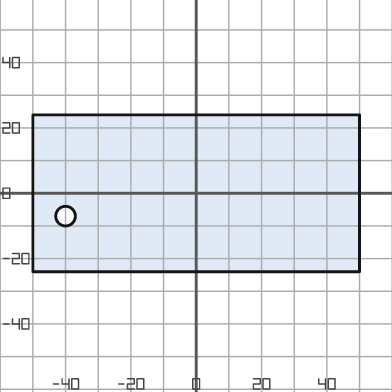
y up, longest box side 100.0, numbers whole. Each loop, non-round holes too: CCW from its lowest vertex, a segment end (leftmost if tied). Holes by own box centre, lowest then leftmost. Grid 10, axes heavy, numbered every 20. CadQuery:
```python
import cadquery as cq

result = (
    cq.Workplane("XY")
    .moveTo(-50.0, -24.0)
    .lineTo(50.0, -24.0)
    .lineTo(50.0, 24.0)
    .lineTo(-50.0, 24.0)
    .close()
    .moveTo(-40.0, -7.0)
    .circle(3.0)
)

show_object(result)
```